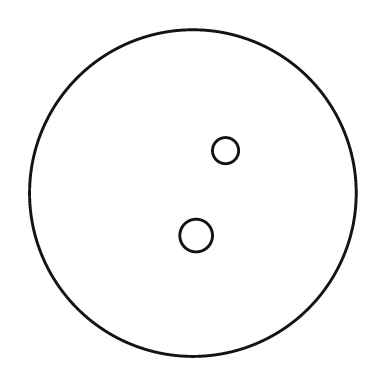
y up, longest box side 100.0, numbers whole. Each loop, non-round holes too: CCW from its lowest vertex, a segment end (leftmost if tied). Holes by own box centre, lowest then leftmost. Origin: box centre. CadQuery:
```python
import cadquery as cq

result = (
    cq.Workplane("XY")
    .moveTo(0.0, 0.0)
    .circle(50.0)
    .moveTo(1.0, -13.0)
    .circle(5.0)
    .moveTo(10.0, 13.0)
    .circle(4.0)
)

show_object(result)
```